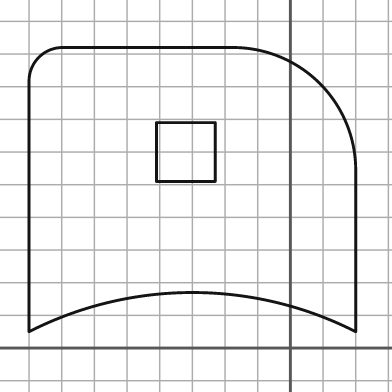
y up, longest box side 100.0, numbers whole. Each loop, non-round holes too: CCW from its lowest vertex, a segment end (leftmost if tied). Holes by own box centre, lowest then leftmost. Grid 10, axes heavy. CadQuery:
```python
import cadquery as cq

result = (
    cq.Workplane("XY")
    .moveTo(-80.0, 5.0)
    .threePointArc((-30.0, 17.0), (20.0, 5.0))
    .lineTo(20.0, 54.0)
    .threePointArc((9.0, 81.0), (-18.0, 92.0))
    .lineTo(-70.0, 92.0)
    .threePointArc((-77.0, 89.0), (-80.0, 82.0))
    .close()
    .moveTo(-41.0, 51.0)
    .lineTo(-23.0, 51.0)
    .lineTo(-23.0, 69.0)
    .lineTo(-41.0, 69.0)
    .close()
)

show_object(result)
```